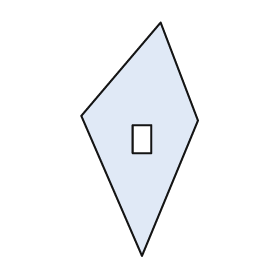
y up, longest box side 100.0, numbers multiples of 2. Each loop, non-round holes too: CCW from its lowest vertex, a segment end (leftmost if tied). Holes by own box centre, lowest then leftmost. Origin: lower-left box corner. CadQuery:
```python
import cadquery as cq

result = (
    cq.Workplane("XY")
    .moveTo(26.0, 0.0)
    .lineTo(50.0, 58.0)
    .lineTo(34.0, 100.0)
    .lineTo(0.0, 60.0)
    .close()
    .moveTo(22.0, 44.0)
    .lineTo(30.0, 44.0)
    .lineTo(30.0, 56.0)
    .lineTo(22.0, 56.0)
    .close()
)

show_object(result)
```